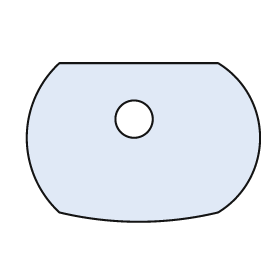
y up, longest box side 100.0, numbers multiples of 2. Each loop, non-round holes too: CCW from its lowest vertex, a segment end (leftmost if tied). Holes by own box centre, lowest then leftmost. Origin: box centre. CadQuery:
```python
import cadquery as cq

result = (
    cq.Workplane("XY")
    .moveTo(-36.0, -30.0)
    .threePointArc((-2.0, -34.0), (32.0, -30.0))
    .threePointArc((50.0, 2.0), (32.0, 34.0))
    .lineTo(-36.0, 34.0)
    .threePointArc((-50.0, 2.0), (-36.0, -30.0))
    .close()
    .moveTo(-4.0, 10.0)
    .circle(8.0)
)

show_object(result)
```